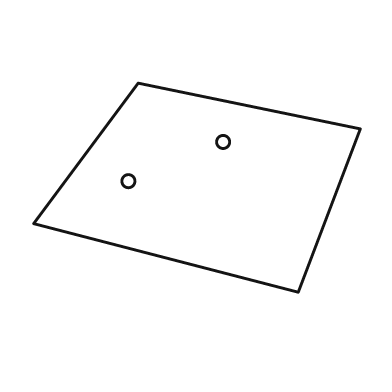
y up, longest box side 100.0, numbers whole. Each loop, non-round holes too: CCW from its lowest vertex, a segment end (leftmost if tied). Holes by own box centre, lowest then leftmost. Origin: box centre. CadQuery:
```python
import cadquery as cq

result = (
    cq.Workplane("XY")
    .moveTo(31.0, -32.0)
    .lineTo(50.0, 18.0)
    .lineTo(-18.0, 32.0)
    .lineTo(-50.0, -11.0)
    .close()
    .moveTo(-21.0, 2.0)
    .circle(2.0)
    .moveTo(8.0, 14.0)
    .circle(2.0)
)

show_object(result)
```